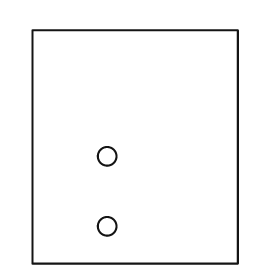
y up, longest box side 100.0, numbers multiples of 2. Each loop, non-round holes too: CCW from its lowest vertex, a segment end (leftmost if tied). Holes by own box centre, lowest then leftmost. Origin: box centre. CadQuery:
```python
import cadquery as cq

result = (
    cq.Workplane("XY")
    .moveTo(-44.0, -50.0)
    .lineTo(44.0, -50.0)
    .lineTo(44.0, 50.0)
    .lineTo(-44.0, 50.0)
    .close()
    .moveTo(-12.0, -34.0)
    .circle(4.0)
    .moveTo(-12.0, -4.0)
    .circle(4.0)
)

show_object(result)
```